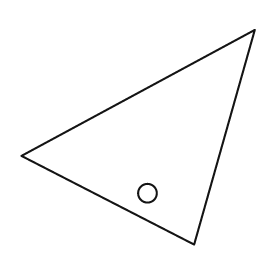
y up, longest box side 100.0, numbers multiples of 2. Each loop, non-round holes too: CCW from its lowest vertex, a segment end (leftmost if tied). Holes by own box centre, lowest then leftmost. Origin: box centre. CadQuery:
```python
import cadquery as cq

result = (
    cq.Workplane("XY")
    .moveTo(24.0, -46.0)
    .lineTo(50.0, 46.0)
    .lineTo(-50.0, -8.0)
    .close()
    .moveTo(4.0, -24.0)
    .circle(4.0)
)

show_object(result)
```